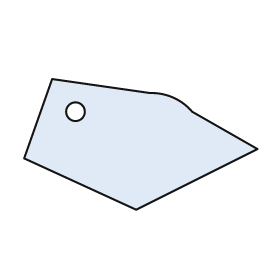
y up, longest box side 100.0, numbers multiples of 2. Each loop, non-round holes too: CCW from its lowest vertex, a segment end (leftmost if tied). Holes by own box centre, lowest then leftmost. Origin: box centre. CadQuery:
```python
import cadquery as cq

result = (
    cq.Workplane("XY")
    .moveTo(-2.0, -28.0)
    .lineTo(50.0, -2.0)
    .lineTo(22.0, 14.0)
    .threePointArc((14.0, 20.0), (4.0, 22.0))
    .lineTo(-38.0, 28.0)
    .lineTo(-50.0, -6.0)
    .close()
    .moveTo(-28.0, 14.0)
    .circle(4.0)
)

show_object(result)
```